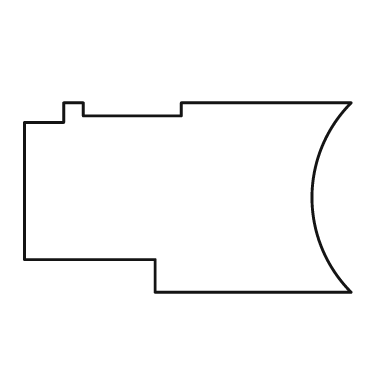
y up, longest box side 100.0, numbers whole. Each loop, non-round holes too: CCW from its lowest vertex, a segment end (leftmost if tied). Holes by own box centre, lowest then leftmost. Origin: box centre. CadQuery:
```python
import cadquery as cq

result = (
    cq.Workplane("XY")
    .moveTo(-10.0, -29.0)
    .lineTo(50.0, -29.0)
    .threePointArc((38.0, 0.0), (50.0, 29.0))
    .lineTo(-2.0, 29.0)
    .lineTo(-2.0, 25.0)
    .lineTo(-32.0, 25.0)
    .lineTo(-32.0, 29.0)
    .lineTo(-38.0, 29.0)
    .lineTo(-38.0, 23.0)
    .lineTo(-50.0, 23.0)
    .lineTo(-50.0, -19.0)
    .lineTo(-10.0, -19.0)
    .close()
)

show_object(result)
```